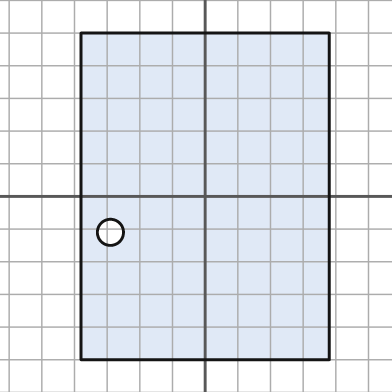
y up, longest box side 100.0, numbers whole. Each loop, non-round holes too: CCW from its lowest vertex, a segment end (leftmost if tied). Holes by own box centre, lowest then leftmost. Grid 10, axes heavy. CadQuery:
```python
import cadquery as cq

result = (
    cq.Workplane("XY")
    .moveTo(-38.0, -50.0)
    .lineTo(38.0, -50.0)
    .lineTo(38.0, 50.0)
    .lineTo(-38.0, 50.0)
    .close()
    .moveTo(-29.0, -11.0)
    .circle(4.0)
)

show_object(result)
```